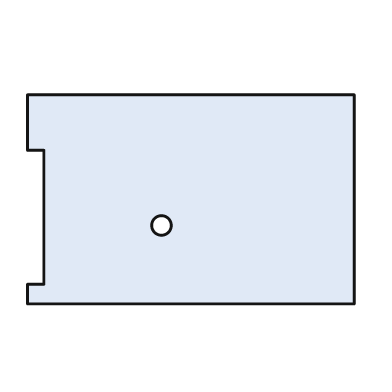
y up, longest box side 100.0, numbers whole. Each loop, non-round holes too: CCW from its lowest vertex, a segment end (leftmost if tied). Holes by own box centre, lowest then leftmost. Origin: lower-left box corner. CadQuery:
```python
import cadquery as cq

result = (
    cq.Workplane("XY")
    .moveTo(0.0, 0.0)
    .lineTo(100.0, 0.0)
    .lineTo(100.0, 64.0)
    .lineTo(0.0, 64.0)
    .lineTo(0.0, 47.0)
    .lineTo(5.0, 47.0)
    .lineTo(5.0, 6.0)
    .lineTo(0.0, 6.0)
    .close()
    .moveTo(41.0, 24.0)
    .circle(3.0)
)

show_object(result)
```